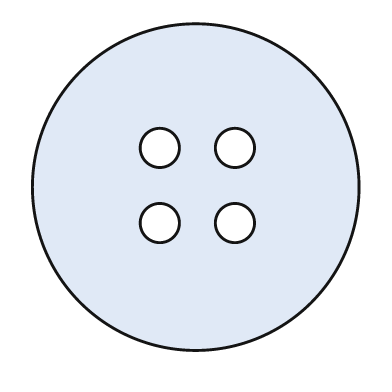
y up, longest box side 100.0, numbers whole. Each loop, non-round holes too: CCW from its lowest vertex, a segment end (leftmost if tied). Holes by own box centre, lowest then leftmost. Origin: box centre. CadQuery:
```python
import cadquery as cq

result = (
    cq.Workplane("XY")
    .moveTo(0.0, 0.0)
    .circle(50.0)
    .moveTo(-11.0, -11.0)
    .circle(6.0)
    .moveTo(12.0, -11.0)
    .circle(6.0)
    .moveTo(-11.0, 12.0)
    .circle(6.0)
    .moveTo(12.0, 12.0)
    .circle(6.0)
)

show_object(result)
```